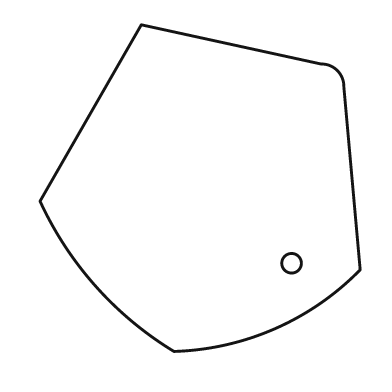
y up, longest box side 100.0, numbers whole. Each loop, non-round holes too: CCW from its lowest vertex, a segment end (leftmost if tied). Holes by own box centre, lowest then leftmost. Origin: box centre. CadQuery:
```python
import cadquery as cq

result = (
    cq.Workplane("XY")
    .moveTo(-8.0, -50.0)
    .threePointArc((23.0, -43.0), (49.0, -25.0))
    .lineTo(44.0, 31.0)
    .threePointArc((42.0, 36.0), (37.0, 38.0))
    .lineTo(-18.0, 50.0)
    .lineTo(-49.0, -4.0)
    .threePointArc((-32.0, -30.0), (-8.0, -50.0))
    .close()
    .moveTo(28.0, -23.0)
    .circle(3.0)
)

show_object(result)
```